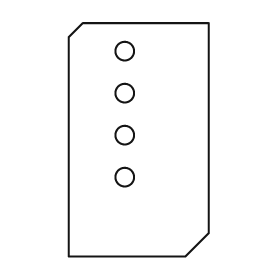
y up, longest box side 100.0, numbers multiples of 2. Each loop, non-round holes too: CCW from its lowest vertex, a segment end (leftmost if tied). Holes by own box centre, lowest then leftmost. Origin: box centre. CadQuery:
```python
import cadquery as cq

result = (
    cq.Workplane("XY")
    .moveTo(-30.0, -50.0)
    .lineTo(20.0, -50.0)
    .lineTo(30.0, -40.0)
    .lineTo(30.0, 50.0)
    .lineTo(-24.0, 50.0)
    .lineTo(-30.0, 44.0)
    .close()
    .moveTo(-6.0, -16.0)
    .circle(4.0)
    .moveTo(-6.0, 2.0)
    .circle(4.0)
    .moveTo(-6.0, 20.0)
    .circle(4.0)
    .moveTo(-6.0, 38.0)
    .circle(4.0)
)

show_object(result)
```